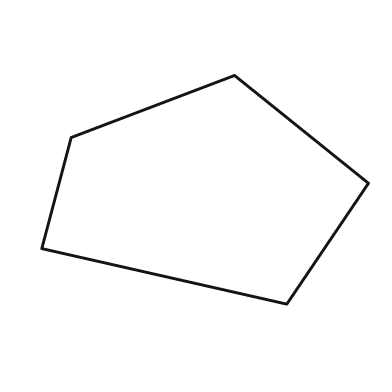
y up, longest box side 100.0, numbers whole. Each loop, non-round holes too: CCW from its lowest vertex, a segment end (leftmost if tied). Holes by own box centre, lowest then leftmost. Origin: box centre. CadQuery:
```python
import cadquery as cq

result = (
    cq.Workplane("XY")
    .moveTo(25.0, -35.0)
    .lineTo(50.0, 2.0)
    .lineTo(9.0, 35.0)
    .lineTo(-41.0, 16.0)
    .lineTo(-50.0, -18.0)
    .close()
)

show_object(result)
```